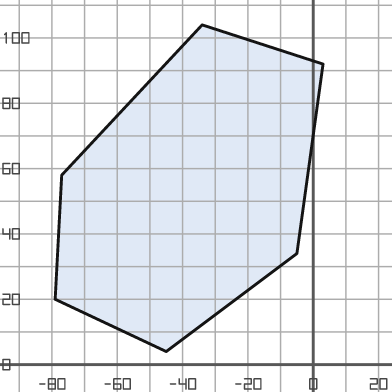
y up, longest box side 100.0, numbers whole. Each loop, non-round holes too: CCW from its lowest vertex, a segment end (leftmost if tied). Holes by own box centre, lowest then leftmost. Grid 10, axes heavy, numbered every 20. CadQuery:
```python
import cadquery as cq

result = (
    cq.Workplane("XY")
    .moveTo(-45.0, 4.0)
    .lineTo(-5.0, 34.0)
    .lineTo(3.0, 92.0)
    .lineTo(-34.0, 104.0)
    .lineTo(-77.0, 58.0)
    .lineTo(-79.0, 20.0)
    .close()
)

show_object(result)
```